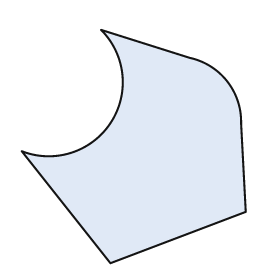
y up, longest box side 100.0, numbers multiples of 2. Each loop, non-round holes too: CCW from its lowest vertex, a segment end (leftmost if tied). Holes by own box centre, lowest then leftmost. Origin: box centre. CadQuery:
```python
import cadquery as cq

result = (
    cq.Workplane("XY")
    .moveTo(-10.0, -50.0)
    .lineTo(48.0, -28.0)
    .lineTo(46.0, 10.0)
    .threePointArc((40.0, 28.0), (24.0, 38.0))
    .lineTo(-14.0, 50.0)
    .threePointArc((-10.0, 10.0), (-48.0, -2.0))
    .close()
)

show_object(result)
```